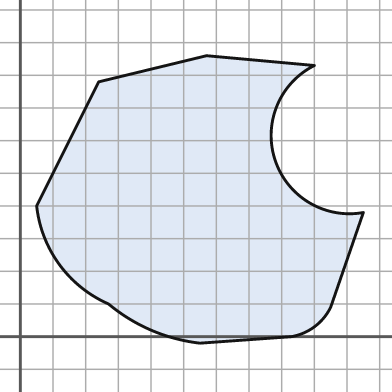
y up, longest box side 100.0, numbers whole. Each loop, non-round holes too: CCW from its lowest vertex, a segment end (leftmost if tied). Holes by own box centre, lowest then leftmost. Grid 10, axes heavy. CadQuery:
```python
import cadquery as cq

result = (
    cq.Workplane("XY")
    .moveTo(55.0, -2.0)
    .lineTo(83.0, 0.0)
    .threePointArc((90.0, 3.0), (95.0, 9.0))
    .lineTo(105.0, 38.0)
    .threePointArc((78.0, 54.0), (90.0, 83.0))
    .lineTo(57.0, 86.0)
    .lineTo(24.0, 78.0)
    .lineTo(5.0, 40.0)
    .threePointArc((12.0, 22.0), (27.0, 10.0))
    .threePointArc((40.0, 2.0), (55.0, -2.0))
    .close()
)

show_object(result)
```